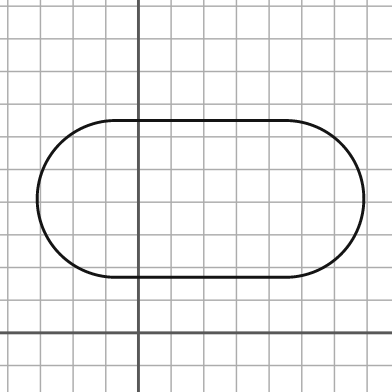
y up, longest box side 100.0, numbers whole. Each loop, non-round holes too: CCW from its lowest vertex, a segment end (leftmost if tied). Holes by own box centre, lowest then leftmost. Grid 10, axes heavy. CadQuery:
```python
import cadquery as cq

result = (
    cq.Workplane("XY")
    .moveTo(-7.0, 17.0)
    .lineTo(45.0, 17.0)
    .threePointArc((69.0, 41.0), (45.0, 65.0))
    .lineTo(-7.0, 65.0)
    .threePointArc((-31.0, 41.0), (-7.0, 17.0))
    .close()
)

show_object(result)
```